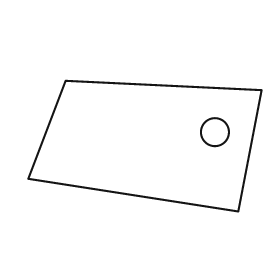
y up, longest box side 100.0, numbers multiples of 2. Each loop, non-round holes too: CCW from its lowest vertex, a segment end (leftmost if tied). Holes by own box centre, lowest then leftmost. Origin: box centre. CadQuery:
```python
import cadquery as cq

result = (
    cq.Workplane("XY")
    .moveTo(40.0, -28.0)
    .lineTo(50.0, 24.0)
    .lineTo(-34.0, 28.0)
    .lineTo(-50.0, -14.0)
    .close()
    .moveTo(30.0, 6.0)
    .circle(6.0)
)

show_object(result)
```